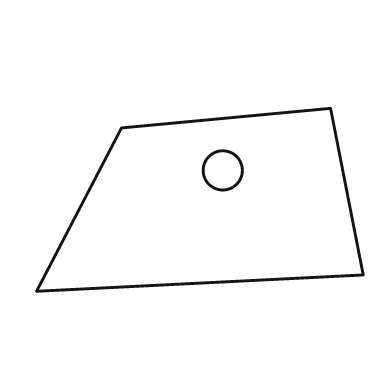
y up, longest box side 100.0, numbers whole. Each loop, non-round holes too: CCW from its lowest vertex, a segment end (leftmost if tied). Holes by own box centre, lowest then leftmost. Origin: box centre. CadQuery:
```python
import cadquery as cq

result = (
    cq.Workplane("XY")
    .moveTo(-50.0, -28.0)
    .lineTo(50.0, -23.0)
    .lineTo(40.0, 28.0)
    .lineTo(-24.0, 22.0)
    .close()
    .moveTo(7.0, 9.0)
    .circle(6.0)
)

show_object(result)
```